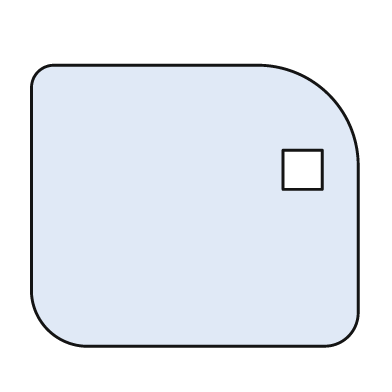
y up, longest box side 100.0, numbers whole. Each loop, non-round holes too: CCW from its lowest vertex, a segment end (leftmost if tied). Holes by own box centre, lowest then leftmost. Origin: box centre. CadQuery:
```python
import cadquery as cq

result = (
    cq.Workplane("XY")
    .moveTo(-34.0, -43.0)
    .lineTo(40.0, -43.0)
    .threePointArc((47.0, -40.0), (50.0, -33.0))
    .lineTo(50.0, 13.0)
    .threePointArc((41.0, 34.0), (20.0, 43.0))
    .lineTo(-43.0, 43.0)
    .threePointArc((-48.0, 41.0), (-50.0, 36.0))
    .lineTo(-50.0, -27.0)
    .threePointArc((-45.0, -38.0), (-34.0, -43.0))
    .close()
    .moveTo(27.0, 5.0)
    .lineTo(39.0, 5.0)
    .lineTo(39.0, 17.0)
    .lineTo(27.0, 17.0)
    .close()
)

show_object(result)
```